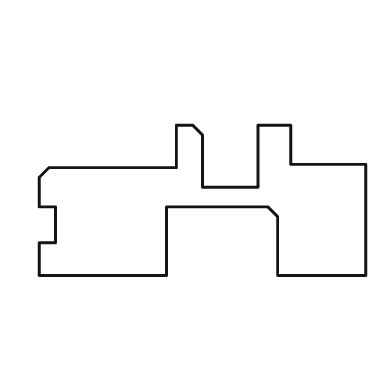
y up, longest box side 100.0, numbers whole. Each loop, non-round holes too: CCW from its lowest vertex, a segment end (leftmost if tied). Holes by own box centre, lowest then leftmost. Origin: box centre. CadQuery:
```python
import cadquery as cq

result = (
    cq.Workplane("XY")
    .moveTo(-50.0, -23.0)
    .lineTo(-11.0, -23.0)
    .lineTo(-11.0, -2.0)
    .lineTo(20.0, -2.0)
    .lineTo(23.0, -5.0)
    .lineTo(23.0, -23.0)
    .lineTo(50.0, -23.0)
    .lineTo(50.0, 11.0)
    .lineTo(27.0, 11.0)
    .lineTo(27.0, 23.0)
    .lineTo(17.0, 23.0)
    .lineTo(17.0, 4.0)
    .lineTo(0.0, 4.0)
    .lineTo(0.0, 20.0)
    .lineTo(-3.0, 23.0)
    .lineTo(-8.0, 23.0)
    .lineTo(-8.0, 10.0)
    .lineTo(-47.0, 10.0)
    .lineTo(-50.0, 7.0)
    .lineTo(-50.0, -2.0)
    .lineTo(-45.0, -2.0)
    .lineTo(-45.0, -13.0)
    .lineTo(-50.0, -13.0)
    .close()
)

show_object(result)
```